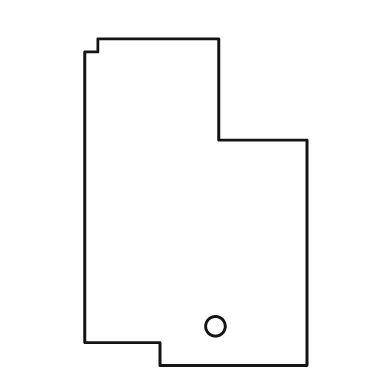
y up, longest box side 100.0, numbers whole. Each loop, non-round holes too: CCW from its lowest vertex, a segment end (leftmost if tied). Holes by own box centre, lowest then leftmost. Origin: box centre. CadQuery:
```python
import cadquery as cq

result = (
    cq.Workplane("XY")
    .moveTo(-11.0, -50.0)
    .lineTo(34.0, -50.0)
    .lineTo(34.0, 19.0)
    .lineTo(7.0, 19.0)
    .lineTo(7.0, 50.0)
    .lineTo(-30.0, 50.0)
    .lineTo(-30.0, 46.0)
    .lineTo(-34.0, 46.0)
    .lineTo(-34.0, -43.0)
    .lineTo(-11.0, -43.0)
    .close()
    .moveTo(6.0, -38.0)
    .circle(3.0)
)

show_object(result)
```